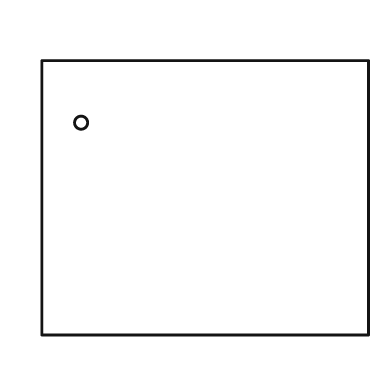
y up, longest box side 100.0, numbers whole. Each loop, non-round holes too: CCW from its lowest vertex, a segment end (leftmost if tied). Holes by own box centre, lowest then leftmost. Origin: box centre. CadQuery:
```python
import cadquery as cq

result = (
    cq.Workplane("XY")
    .moveTo(-50.0, -42.0)
    .lineTo(50.0, -42.0)
    .lineTo(50.0, 42.0)
    .lineTo(-50.0, 42.0)
    .close()
    .moveTo(-38.0, 23.0)
    .circle(2.0)
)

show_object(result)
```